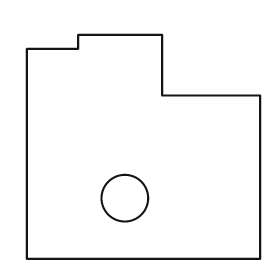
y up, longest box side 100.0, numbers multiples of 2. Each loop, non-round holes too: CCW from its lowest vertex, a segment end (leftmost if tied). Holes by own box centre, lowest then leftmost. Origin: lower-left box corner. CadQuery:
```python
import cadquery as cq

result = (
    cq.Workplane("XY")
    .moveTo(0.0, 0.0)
    .lineTo(100.0, 0.0)
    .lineTo(100.0, 70.0)
    .lineTo(58.0, 70.0)
    .lineTo(58.0, 96.0)
    .lineTo(22.0, 96.0)
    .lineTo(22.0, 90.0)
    .lineTo(0.0, 90.0)
    .close()
    .moveTo(42.0, 26.0)
    .circle(10.0)
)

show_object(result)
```